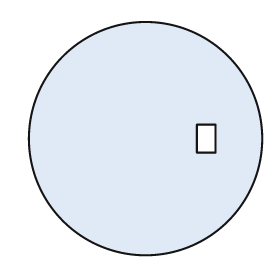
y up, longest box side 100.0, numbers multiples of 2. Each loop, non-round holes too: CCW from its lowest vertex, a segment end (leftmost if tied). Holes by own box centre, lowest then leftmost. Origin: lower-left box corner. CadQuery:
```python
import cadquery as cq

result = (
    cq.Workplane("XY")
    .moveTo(50.0, 50.0)
    .circle(50.0)
    .moveTo(72.0, 44.0)
    .lineTo(80.0, 44.0)
    .lineTo(80.0, 56.0)
    .lineTo(72.0, 56.0)
    .close()
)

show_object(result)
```